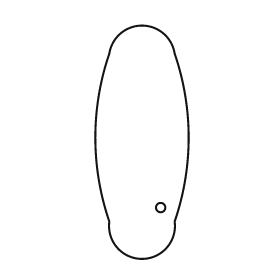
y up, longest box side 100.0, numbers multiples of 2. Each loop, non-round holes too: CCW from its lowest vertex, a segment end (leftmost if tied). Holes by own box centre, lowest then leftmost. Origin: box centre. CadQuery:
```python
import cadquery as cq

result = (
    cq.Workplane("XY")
    .moveTo(-14.0, -34.0)
    .threePointArc((0.0, -50.0), (14.0, -34.0))
    .threePointArc((20.0, 2.0), (14.0, 38.0))
    .threePointArc((0.0, 50.0), (-14.0, 38.0))
    .threePointArc((-20.0, 2.0), (-14.0, -34.0))
    .close()
    .moveTo(8.0, -28.0)
    .circle(2.0)
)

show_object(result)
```